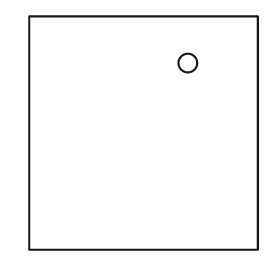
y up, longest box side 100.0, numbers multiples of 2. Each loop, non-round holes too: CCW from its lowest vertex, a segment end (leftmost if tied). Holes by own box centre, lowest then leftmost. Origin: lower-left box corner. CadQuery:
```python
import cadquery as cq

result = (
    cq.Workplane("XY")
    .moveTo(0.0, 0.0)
    .lineTo(98.0, 0.0)
    .lineTo(98.0, 100.0)
    .lineTo(0.0, 100.0)
    .close()
    .moveTo(68.0, 80.0)
    .circle(4.0)
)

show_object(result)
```